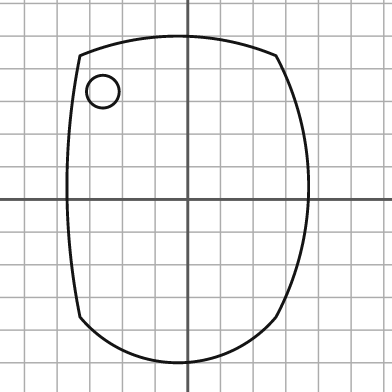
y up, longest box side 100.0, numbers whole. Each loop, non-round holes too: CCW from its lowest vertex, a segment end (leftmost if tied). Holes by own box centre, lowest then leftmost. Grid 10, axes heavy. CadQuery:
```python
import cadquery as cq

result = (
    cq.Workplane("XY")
    .moveTo(-33.0, -36.0)
    .threePointArc((-3.0, -50.0), (27.0, -36.0))
    .threePointArc((37.0, 4.0), (27.0, 44.0))
    .threePointArc((-3.0, 50.0), (-33.0, 44.0))
    .threePointArc((-37.0, 4.0), (-33.0, -36.0))
    .close()
    .moveTo(-26.0, 33.0)
    .circle(5.0)
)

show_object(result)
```